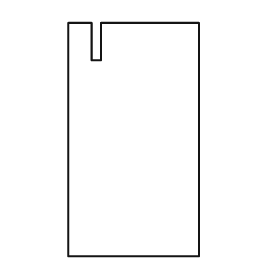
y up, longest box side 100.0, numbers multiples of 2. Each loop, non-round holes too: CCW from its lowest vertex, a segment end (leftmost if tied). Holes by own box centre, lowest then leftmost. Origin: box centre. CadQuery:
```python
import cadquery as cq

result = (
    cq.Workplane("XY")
    .moveTo(-28.0, -50.0)
    .lineTo(28.0, -50.0)
    .lineTo(28.0, 50.0)
    .lineTo(-14.0, 50.0)
    .lineTo(-14.0, 34.0)
    .lineTo(-18.0, 34.0)
    .lineTo(-18.0, 50.0)
    .lineTo(-28.0, 50.0)
    .close()
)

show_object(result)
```